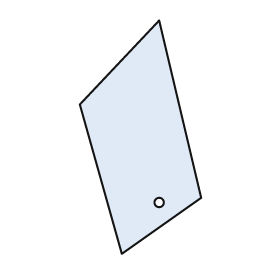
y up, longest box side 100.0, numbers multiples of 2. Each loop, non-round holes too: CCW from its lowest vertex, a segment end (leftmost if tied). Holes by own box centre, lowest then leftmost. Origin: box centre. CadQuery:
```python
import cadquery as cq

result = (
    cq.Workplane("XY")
    .moveTo(-8.0, -50.0)
    .lineTo(26.0, -26.0)
    .lineTo(8.0, 50.0)
    .lineTo(-26.0, 14.0)
    .close()
    .moveTo(8.0, -28.0)
    .circle(2.0)
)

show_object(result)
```